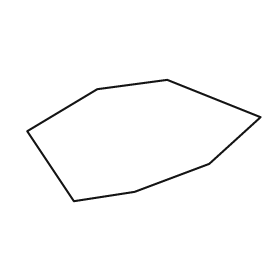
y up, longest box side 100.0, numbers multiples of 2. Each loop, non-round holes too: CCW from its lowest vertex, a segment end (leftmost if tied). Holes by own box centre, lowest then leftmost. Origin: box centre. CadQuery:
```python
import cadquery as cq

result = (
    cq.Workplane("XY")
    .moveTo(-30.0, -26.0)
    .lineTo(-4.0, -22.0)
    .lineTo(28.0, -10.0)
    .lineTo(50.0, 10.0)
    .lineTo(10.0, 26.0)
    .lineTo(-20.0, 22.0)
    .lineTo(-50.0, 4.0)
    .close()
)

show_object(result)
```